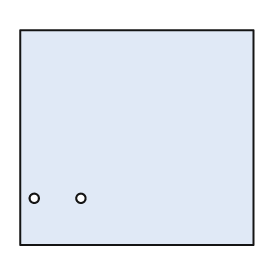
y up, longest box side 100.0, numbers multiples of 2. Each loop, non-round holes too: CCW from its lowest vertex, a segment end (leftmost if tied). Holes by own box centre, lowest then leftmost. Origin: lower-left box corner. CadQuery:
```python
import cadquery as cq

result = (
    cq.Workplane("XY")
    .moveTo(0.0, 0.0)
    .lineTo(100.0, 0.0)
    .lineTo(100.0, 92.0)
    .lineTo(0.0, 92.0)
    .close()
    .moveTo(6.0, 20.0)
    .circle(2.0)
    .moveTo(26.0, 20.0)
    .circle(2.0)
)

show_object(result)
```